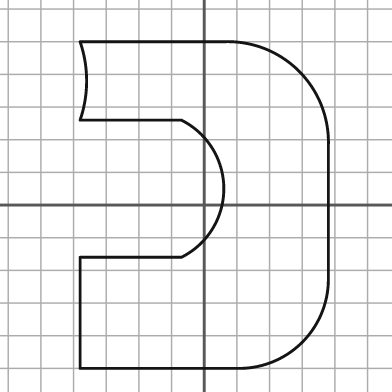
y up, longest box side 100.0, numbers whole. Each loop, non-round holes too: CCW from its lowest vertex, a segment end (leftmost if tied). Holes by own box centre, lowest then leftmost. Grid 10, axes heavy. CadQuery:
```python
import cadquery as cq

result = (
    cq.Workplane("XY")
    .moveTo(-38.0, -50.0)
    .lineTo(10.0, -50.0)
    .threePointArc((30.0, -42.0), (38.0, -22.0))
    .lineTo(38.0, 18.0)
    .threePointArc((29.0, 41.0), (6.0, 50.0))
    .lineTo(-38.0, 50.0)
    .threePointArc((-36.0, 38.0), (-38.0, 26.0))
    .lineTo(-7.0, 26.0)
    .threePointArc((6.0, 5.0), (-7.0, -16.0))
    .lineTo(-38.0, -16.0)
    .close()
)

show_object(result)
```